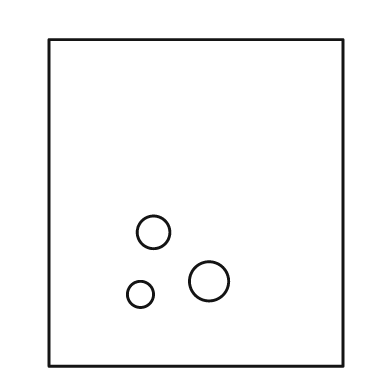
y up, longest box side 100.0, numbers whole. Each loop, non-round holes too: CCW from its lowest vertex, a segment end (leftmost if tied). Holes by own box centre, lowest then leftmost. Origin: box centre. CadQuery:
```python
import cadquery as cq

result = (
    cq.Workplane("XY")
    .moveTo(-45.0, -50.0)
    .lineTo(45.0, -50.0)
    .lineTo(45.0, 50.0)
    .lineTo(-45.0, 50.0)
    .close()
    .moveTo(-17.0, -28.0)
    .circle(4.0)
    .moveTo(4.0, -24.0)
    .circle(6.0)
    .moveTo(-13.0, -9.0)
    .circle(5.0)
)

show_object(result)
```